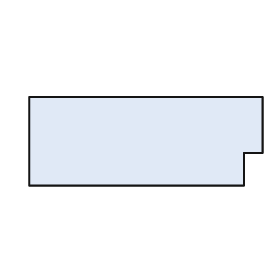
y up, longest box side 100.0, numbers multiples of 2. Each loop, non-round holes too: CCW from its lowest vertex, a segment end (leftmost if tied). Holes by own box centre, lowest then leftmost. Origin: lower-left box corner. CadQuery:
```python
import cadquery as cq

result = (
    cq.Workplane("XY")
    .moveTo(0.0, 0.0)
    .lineTo(92.0, 0.0)
    .lineTo(92.0, 14.0)
    .lineTo(100.0, 14.0)
    .lineTo(100.0, 38.0)
    .lineTo(0.0, 38.0)
    .close()
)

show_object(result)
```